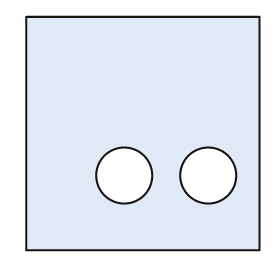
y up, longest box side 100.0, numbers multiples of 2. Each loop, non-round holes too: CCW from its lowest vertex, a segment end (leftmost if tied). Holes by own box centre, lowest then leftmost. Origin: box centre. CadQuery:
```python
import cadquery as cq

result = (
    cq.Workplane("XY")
    .moveTo(-50.0, -50.0)
    .lineTo(50.0, -50.0)
    .lineTo(50.0, 50.0)
    .lineTo(-50.0, 50.0)
    .close()
    .moveTo(-8.0, -18.0)
    .circle(12.0)
    .moveTo(28.0, -18.0)
    .circle(12.0)
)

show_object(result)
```